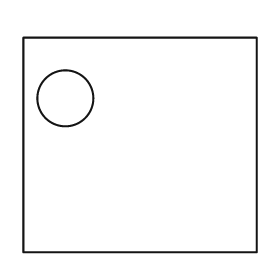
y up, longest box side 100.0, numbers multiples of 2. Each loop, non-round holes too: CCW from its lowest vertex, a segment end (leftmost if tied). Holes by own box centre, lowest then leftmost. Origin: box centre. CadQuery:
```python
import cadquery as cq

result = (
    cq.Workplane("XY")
    .moveTo(-50.0, -46.0)
    .lineTo(50.0, -46.0)
    .lineTo(50.0, 46.0)
    .lineTo(-50.0, 46.0)
    .close()
    .moveTo(-32.0, 20.0)
    .circle(12.0)
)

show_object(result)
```